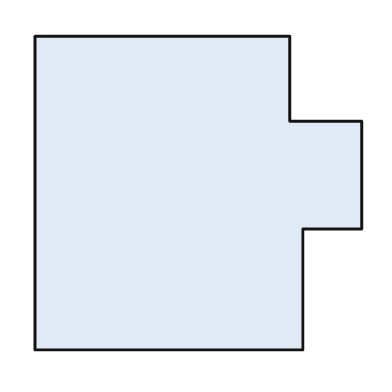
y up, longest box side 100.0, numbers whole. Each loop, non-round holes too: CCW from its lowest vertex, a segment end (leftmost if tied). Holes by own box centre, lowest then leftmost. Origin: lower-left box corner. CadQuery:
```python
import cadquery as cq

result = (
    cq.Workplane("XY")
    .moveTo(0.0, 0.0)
    .lineTo(82.0, 0.0)
    .lineTo(82.0, 37.0)
    .lineTo(100.0, 37.0)
    .lineTo(100.0, 70.0)
    .lineTo(78.0, 70.0)
    .lineTo(78.0, 96.0)
    .lineTo(0.0, 96.0)
    .close()
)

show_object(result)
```